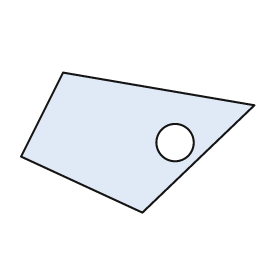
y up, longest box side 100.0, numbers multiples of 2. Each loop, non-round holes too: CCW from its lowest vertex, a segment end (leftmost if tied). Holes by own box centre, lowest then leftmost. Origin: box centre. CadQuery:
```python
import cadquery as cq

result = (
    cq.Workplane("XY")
    .moveTo(2.0, -30.0)
    .lineTo(50.0, 16.0)
    .lineTo(-32.0, 30.0)
    .lineTo(-50.0, -6.0)
    .close()
    .moveTo(16.0, 0.0)
    .circle(8.0)
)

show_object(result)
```